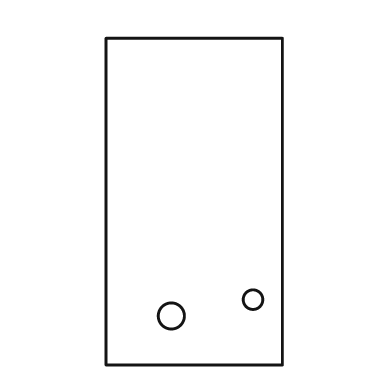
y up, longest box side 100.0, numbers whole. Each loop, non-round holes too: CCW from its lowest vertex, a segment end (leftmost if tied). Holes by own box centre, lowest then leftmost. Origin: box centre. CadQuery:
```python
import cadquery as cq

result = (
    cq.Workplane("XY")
    .moveTo(-27.0, -50.0)
    .lineTo(27.0, -50.0)
    .lineTo(27.0, 50.0)
    .lineTo(-27.0, 50.0)
    .close()
    .moveTo(-7.0, -35.0)
    .circle(4.0)
    .moveTo(18.0, -30.0)
    .circle(3.0)
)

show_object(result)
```